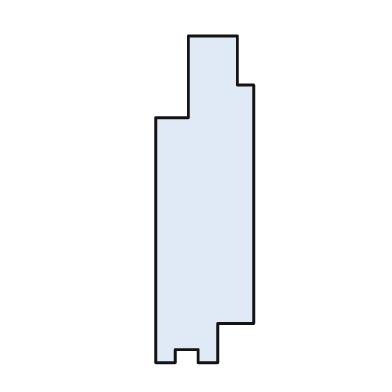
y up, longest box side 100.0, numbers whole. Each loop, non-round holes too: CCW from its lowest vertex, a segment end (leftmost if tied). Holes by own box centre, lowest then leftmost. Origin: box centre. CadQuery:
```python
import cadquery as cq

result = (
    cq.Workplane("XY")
    .moveTo(-15.0, -50.0)
    .lineTo(-9.0, -50.0)
    .lineTo(-9.0, -46.0)
    .lineTo(-2.0, -46.0)
    .lineTo(-2.0, -50.0)
    .lineTo(4.0, -50.0)
    .lineTo(4.0, -38.0)
    .lineTo(15.0, -38.0)
    .lineTo(15.0, 35.0)
    .lineTo(10.0, 35.0)
    .lineTo(10.0, 50.0)
    .lineTo(-5.0, 50.0)
    .lineTo(-5.0, 25.0)
    .lineTo(-15.0, 25.0)
    .close()
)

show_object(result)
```